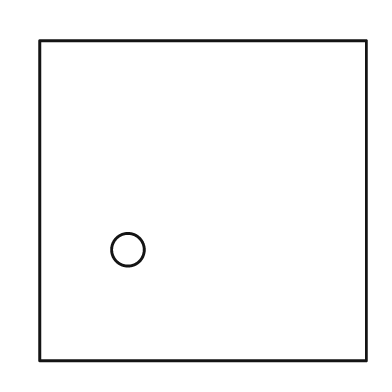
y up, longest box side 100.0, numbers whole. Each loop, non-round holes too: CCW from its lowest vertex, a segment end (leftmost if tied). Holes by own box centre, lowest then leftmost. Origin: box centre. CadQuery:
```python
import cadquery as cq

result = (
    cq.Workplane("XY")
    .moveTo(-50.0, -49.0)
    .lineTo(50.0, -49.0)
    .lineTo(50.0, 49.0)
    .lineTo(-50.0, 49.0)
    .close()
    .moveTo(-23.0, -15.0)
    .circle(5.0)
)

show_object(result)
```